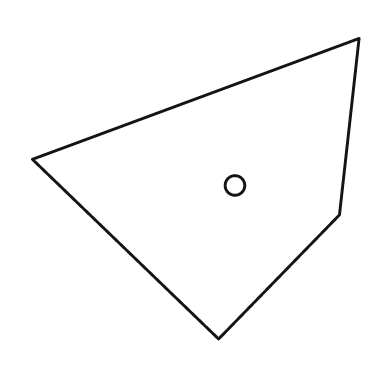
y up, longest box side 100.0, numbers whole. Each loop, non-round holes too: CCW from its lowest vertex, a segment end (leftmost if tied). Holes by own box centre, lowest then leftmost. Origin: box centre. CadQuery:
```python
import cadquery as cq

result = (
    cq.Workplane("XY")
    .moveTo(7.0, -46.0)
    .lineTo(44.0, -8.0)
    .lineTo(50.0, 46.0)
    .lineTo(-50.0, 9.0)
    .close()
    .moveTo(12.0, 1.0)
    .circle(3.0)
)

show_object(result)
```